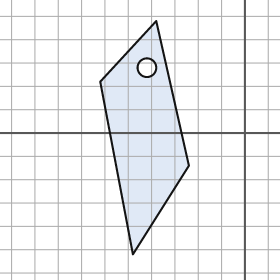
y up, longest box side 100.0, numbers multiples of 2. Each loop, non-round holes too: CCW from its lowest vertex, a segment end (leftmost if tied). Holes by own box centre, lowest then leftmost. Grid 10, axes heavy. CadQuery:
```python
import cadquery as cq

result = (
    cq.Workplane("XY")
    .moveTo(-48.0, -52.0)
    .lineTo(-24.0, -14.0)
    .lineTo(-38.0, 48.0)
    .lineTo(-62.0, 22.0)
    .close()
    .moveTo(-42.0, 28.0)
    .circle(4.0)
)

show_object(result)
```